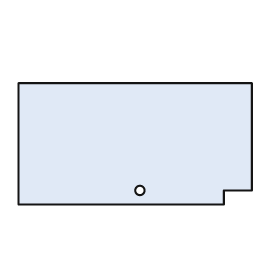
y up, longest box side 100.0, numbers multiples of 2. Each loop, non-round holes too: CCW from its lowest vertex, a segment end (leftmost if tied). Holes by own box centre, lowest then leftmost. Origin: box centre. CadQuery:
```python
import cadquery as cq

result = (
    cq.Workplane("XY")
    .moveTo(-50.0, -26.0)
    .lineTo(38.0, -26.0)
    .lineTo(38.0, -20.0)
    .lineTo(50.0, -20.0)
    .lineTo(50.0, 26.0)
    .lineTo(-50.0, 26.0)
    .close()
    .moveTo(2.0, -20.0)
    .circle(2.0)
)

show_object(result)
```